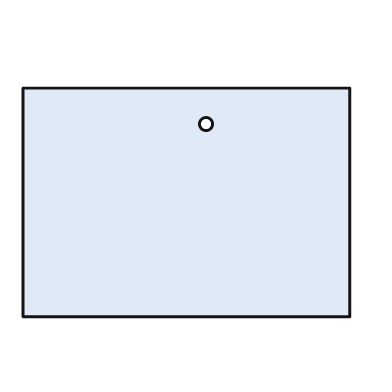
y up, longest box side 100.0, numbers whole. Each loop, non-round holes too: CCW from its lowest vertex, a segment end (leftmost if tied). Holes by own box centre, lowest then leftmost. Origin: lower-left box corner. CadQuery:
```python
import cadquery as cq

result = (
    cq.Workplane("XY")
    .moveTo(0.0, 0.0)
    .lineTo(100.0, 0.0)
    .lineTo(100.0, 70.0)
    .lineTo(0.0, 70.0)
    .close()
    .moveTo(56.0, 59.0)
    .circle(2.0)
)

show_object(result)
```